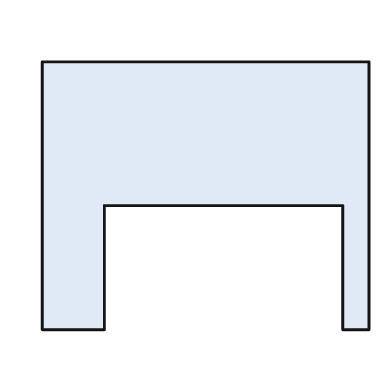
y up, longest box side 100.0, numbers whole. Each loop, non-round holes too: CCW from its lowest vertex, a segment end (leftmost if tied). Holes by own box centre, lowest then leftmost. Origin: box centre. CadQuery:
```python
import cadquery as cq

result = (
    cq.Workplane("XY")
    .moveTo(-50.0, -41.0)
    .lineTo(-31.0, -41.0)
    .lineTo(-31.0, -3.0)
    .lineTo(42.0, -3.0)
    .lineTo(42.0, -41.0)
    .lineTo(50.0, -41.0)
    .lineTo(50.0, 41.0)
    .lineTo(-50.0, 41.0)
    .close()
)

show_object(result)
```